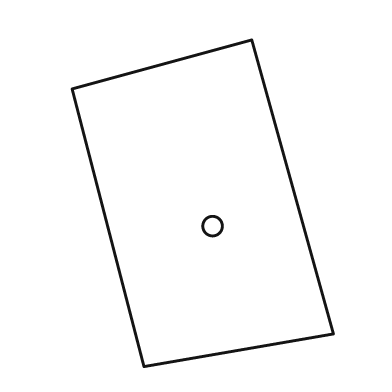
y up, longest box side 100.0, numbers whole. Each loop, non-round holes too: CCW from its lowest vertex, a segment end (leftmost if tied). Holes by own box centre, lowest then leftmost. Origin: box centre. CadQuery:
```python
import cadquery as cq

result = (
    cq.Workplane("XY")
    .moveTo(-18.0, -50.0)
    .lineTo(40.0, -40.0)
    .lineTo(15.0, 50.0)
    .lineTo(-40.0, 35.0)
    .close()
    .moveTo(3.0, -7.0)
    .circle(3.0)
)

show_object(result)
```